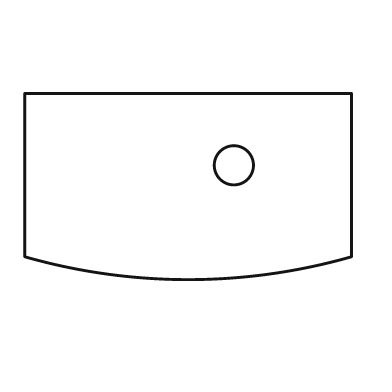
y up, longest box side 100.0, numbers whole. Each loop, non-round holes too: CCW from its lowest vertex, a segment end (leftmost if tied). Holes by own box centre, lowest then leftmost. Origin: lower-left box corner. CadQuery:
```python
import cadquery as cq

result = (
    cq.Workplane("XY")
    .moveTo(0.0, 7.0)
    .threePointArc((50.0, 0.0), (100.0, 7.0))
    .lineTo(100.0, 57.0)
    .lineTo(0.0, 57.0)
    .close()
    .moveTo(64.0, 35.0)
    .circle(6.0)
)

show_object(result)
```